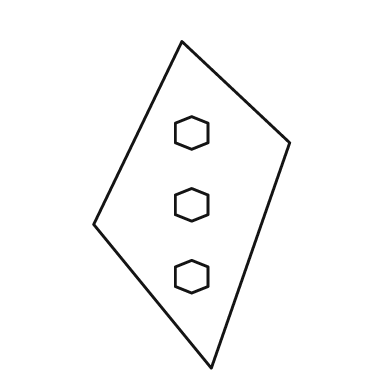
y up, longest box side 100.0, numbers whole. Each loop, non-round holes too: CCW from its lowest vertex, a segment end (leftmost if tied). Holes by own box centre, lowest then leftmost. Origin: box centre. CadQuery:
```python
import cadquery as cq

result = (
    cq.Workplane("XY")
    .moveTo(6.0, -50.0)
    .lineTo(30.0, 19.0)
    .lineTo(-3.0, 50.0)
    .lineTo(-30.0, -6.0)
    .close()
    .moveTo(0.0, -27.0)
    .lineTo(5.0, -25.0)
    .lineTo(5.0, -19.0)
    .lineTo(0.0, -17.0)
    .lineTo(-5.0, -19.0)
    .lineTo(-5.0, -25.0)
    .close()
    .moveTo(0.0, -5.0)
    .lineTo(5.0, -3.0)
    .lineTo(5.0, 3.0)
    .lineTo(0.0, 5.0)
    .lineTo(-5.0, 3.0)
    .lineTo(-5.0, -3.0)
    .close()
    .moveTo(0.0, 17.0)
    .lineTo(5.0, 19.0)
    .lineTo(5.0, 25.0)
    .lineTo(0.0, 27.0)
    .lineTo(-5.0, 25.0)
    .lineTo(-5.0, 19.0)
    .close()
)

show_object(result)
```